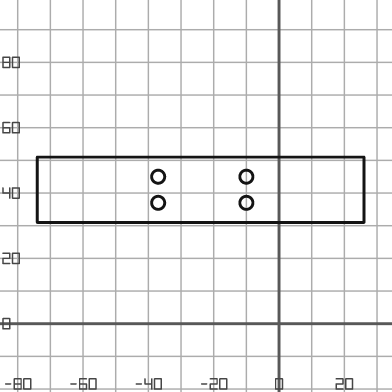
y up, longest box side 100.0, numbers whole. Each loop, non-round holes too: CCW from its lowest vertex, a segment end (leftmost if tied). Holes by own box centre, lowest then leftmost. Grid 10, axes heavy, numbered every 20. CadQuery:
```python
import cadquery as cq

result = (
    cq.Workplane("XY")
    .moveTo(-74.0, 31.0)
    .lineTo(26.0, 31.0)
    .lineTo(26.0, 51.0)
    .lineTo(-74.0, 51.0)
    .close()
    .moveTo(-37.0, 37.0)
    .circle(2.0)
    .moveTo(-10.0, 37.0)
    .circle(2.0)
    .moveTo(-37.0, 45.0)
    .circle(2.0)
    .moveTo(-10.0, 45.0)
    .circle(2.0)
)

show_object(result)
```